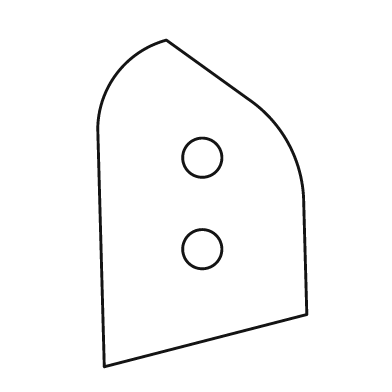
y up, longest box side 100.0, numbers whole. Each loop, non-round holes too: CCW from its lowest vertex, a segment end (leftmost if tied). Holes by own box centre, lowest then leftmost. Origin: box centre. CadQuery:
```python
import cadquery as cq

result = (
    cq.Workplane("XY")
    .moveTo(-30.0, -50.0)
    .lineTo(32.0, -34.0)
    .lineTo(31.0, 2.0)
    .threePointArc((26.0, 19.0), (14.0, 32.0))
    .lineTo(-11.0, 50.0)
    .threePointArc((-26.0, 40.0), (-32.0, 23.0))
    .close()
    .moveTo(0.0, -14.0)
    .circle(6.0)
    .moveTo(0.0, 14.0)
    .circle(6.0)
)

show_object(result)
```